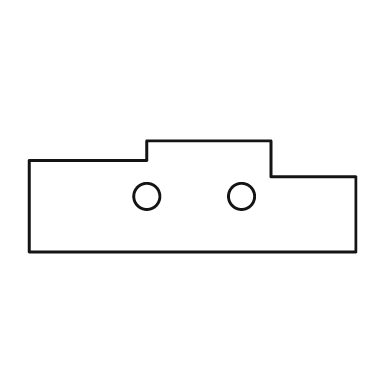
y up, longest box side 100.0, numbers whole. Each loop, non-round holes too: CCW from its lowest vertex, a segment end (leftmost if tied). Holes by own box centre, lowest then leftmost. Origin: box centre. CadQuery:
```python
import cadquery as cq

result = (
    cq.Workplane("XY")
    .moveTo(-50.0, -17.0)
    .lineTo(50.0, -17.0)
    .lineTo(50.0, 6.0)
    .lineTo(24.0, 6.0)
    .lineTo(24.0, 17.0)
    .lineTo(-14.0, 17.0)
    .lineTo(-14.0, 11.0)
    .lineTo(-50.0, 11.0)
    .close()
    .moveTo(-14.0, 0.0)
    .circle(4.0)
    .moveTo(15.0, 0.0)
    .circle(4.0)
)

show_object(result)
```